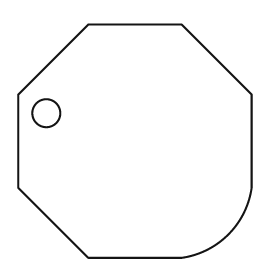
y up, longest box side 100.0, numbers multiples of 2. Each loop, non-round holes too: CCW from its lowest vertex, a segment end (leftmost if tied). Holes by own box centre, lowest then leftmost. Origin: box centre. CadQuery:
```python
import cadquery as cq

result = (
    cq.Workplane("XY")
    .moveTo(-20.0, -50.0)
    .lineTo(20.0, -50.0)
    .threePointArc((40.0, -40.0), (50.0, -20.0))
    .lineTo(50.0, 20.0)
    .lineTo(20.0, 50.0)
    .lineTo(-20.0, 50.0)
    .lineTo(-50.0, 20.0)
    .lineTo(-50.0, -20.0)
    .close()
    .moveTo(-38.0, 12.0)
    .circle(6.0)
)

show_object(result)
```